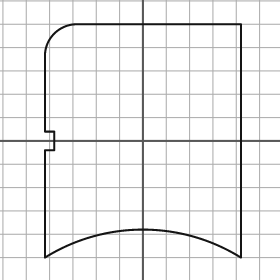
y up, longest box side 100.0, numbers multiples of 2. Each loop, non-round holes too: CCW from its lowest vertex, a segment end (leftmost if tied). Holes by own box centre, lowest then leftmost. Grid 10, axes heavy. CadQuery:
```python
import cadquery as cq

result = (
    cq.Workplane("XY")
    .moveTo(-42.0, -50.0)
    .threePointArc((0.0, -38.0), (42.0, -50.0))
    .lineTo(42.0, 50.0)
    .lineTo(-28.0, 50.0)
    .threePointArc((-38.0, 46.0), (-42.0, 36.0))
    .lineTo(-42.0, 4.0)
    .lineTo(-38.0, 4.0)
    .lineTo(-38.0, -4.0)
    .lineTo(-42.0, -4.0)
    .close()
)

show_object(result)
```